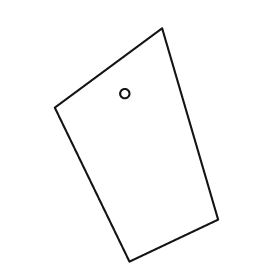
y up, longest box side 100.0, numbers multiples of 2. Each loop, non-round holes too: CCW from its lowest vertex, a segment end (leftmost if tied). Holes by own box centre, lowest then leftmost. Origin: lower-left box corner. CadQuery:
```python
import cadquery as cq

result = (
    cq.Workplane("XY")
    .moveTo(32.0, 0.0)
    .lineTo(70.0, 18.0)
    .lineTo(46.0, 100.0)
    .lineTo(0.0, 66.0)
    .close()
    .moveTo(30.0, 72.0)
    .circle(2.0)
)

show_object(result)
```